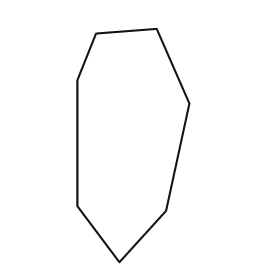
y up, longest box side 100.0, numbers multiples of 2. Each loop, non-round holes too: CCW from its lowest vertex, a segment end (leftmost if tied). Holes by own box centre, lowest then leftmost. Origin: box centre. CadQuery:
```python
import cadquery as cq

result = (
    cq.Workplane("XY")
    .moveTo(-6.0, -50.0)
    .lineTo(14.0, -28.0)
    .lineTo(24.0, 18.0)
    .lineTo(10.0, 50.0)
    .lineTo(-16.0, 48.0)
    .lineTo(-24.0, 28.0)
    .lineTo(-24.0, -26.0)
    .close()
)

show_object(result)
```